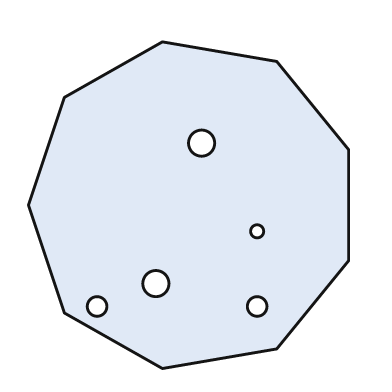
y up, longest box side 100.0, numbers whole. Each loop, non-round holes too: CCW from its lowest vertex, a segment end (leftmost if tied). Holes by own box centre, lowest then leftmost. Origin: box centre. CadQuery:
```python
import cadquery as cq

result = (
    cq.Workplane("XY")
    .moveTo(-8.0, -50.0)
    .lineTo(27.0, -44.0)
    .lineTo(49.0, -17.0)
    .lineTo(49.0, 17.0)
    .lineTo(27.0, 44.0)
    .lineTo(-8.0, 50.0)
    .lineTo(-38.0, 33.0)
    .lineTo(-49.0, 0.0)
    .lineTo(-38.0, -33.0)
    .close()
    .moveTo(-28.0, -31.0)
    .circle(3.0)
    .moveTo(21.0, -31.0)
    .circle(3.0)
    .moveTo(-10.0, -24.0)
    .circle(4.0)
    .moveTo(21.0, -8.0)
    .circle(2.0)
    .moveTo(4.0, 19.0)
    .circle(4.0)
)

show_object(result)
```